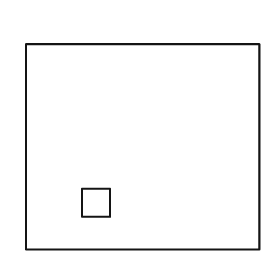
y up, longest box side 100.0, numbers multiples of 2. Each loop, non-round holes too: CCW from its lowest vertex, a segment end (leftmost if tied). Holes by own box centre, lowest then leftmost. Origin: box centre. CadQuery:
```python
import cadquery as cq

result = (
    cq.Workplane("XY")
    .moveTo(-50.0, -44.0)
    .lineTo(50.0, -44.0)
    .lineTo(50.0, 44.0)
    .lineTo(-50.0, 44.0)
    .close()
    .moveTo(-26.0, -30.0)
    .lineTo(-14.0, -30.0)
    .lineTo(-14.0, -18.0)
    .lineTo(-26.0, -18.0)
    .close()
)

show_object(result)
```